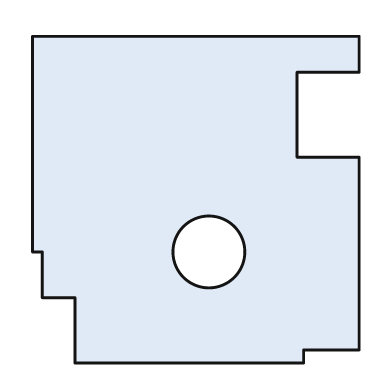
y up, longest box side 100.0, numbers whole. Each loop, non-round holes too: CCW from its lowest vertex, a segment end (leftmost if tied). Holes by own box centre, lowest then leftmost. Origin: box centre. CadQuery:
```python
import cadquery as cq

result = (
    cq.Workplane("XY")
    .moveTo(-37.0, -50.0)
    .lineTo(33.0, -50.0)
    .lineTo(33.0, -46.0)
    .lineTo(50.0, -46.0)
    .lineTo(50.0, 13.0)
    .lineTo(31.0, 13.0)
    .lineTo(31.0, 39.0)
    .lineTo(50.0, 39.0)
    .lineTo(50.0, 50.0)
    .lineTo(-50.0, 50.0)
    .lineTo(-50.0, -16.0)
    .lineTo(-47.0, -16.0)
    .lineTo(-47.0, -30.0)
    .lineTo(-37.0, -30.0)
    .close()
    .moveTo(4.0, -16.0)
    .circle(11.0)
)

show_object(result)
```